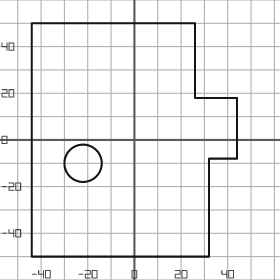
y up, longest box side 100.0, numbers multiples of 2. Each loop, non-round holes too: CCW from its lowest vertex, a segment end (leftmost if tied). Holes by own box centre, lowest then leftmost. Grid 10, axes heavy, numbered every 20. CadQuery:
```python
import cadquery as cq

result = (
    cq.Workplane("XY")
    .moveTo(-44.0, -50.0)
    .lineTo(32.0, -50.0)
    .lineTo(32.0, -8.0)
    .lineTo(44.0, -8.0)
    .lineTo(44.0, 18.0)
    .lineTo(26.0, 18.0)
    .lineTo(26.0, 50.0)
    .lineTo(-44.0, 50.0)
    .close()
    .moveTo(-22.0, -10.0)
    .circle(8.0)
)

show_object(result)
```